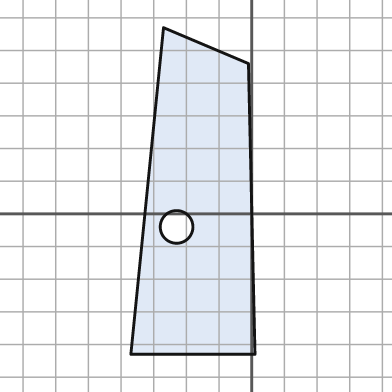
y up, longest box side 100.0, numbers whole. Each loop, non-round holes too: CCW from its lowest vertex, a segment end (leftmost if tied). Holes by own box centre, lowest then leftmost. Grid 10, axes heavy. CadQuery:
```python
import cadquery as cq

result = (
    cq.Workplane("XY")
    .moveTo(-37.0, -43.0)
    .lineTo(1.0, -43.0)
    .lineTo(-1.0, 46.0)
    .lineTo(-27.0, 57.0)
    .close()
    .moveTo(-23.0, -4.0)
    .circle(5.0)
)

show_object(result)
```